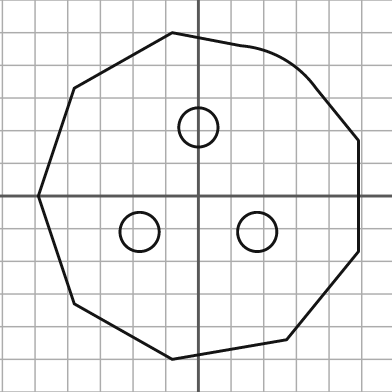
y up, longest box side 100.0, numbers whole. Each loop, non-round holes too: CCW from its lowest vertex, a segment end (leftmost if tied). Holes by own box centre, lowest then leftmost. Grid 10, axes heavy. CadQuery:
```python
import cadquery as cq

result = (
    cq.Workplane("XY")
    .moveTo(-8.0, -50.0)
    .lineTo(27.0, -44.0)
    .lineTo(49.0, -17.0)
    .lineTo(49.0, 17.0)
    .lineTo(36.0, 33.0)
    .threePointArc((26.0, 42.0), (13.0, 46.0))
    .lineTo(-8.0, 50.0)
    .lineTo(-38.0, 33.0)
    .lineTo(-49.0, 0.0)
    .lineTo(-38.0, -33.0)
    .close()
    .moveTo(-18.0, -11.0)
    .circle(6.0)
    .moveTo(18.0, -11.0)
    .circle(6.0)
    .moveTo(0.0, 21.0)
    .circle(6.0)
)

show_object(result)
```